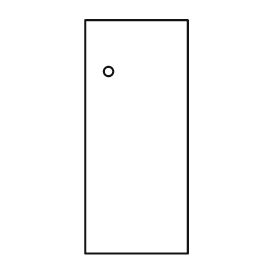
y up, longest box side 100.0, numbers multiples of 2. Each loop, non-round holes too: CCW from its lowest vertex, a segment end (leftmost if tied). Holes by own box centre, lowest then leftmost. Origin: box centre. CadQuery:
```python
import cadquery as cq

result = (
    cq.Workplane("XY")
    .moveTo(-22.0, -50.0)
    .lineTo(22.0, -50.0)
    .lineTo(22.0, 50.0)
    .lineTo(-22.0, 50.0)
    .close()
    .moveTo(-12.0, 28.0)
    .circle(2.0)
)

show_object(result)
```